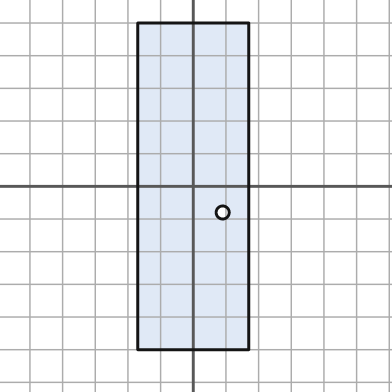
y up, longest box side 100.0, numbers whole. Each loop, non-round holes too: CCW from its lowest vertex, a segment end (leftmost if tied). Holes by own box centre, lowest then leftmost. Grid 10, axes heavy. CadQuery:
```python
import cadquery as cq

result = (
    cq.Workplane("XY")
    .moveTo(-17.0, -50.0)
    .lineTo(17.0, -50.0)
    .lineTo(17.0, 50.0)
    .lineTo(-17.0, 50.0)
    .close()
    .moveTo(9.0, -8.0)
    .circle(2.0)
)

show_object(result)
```